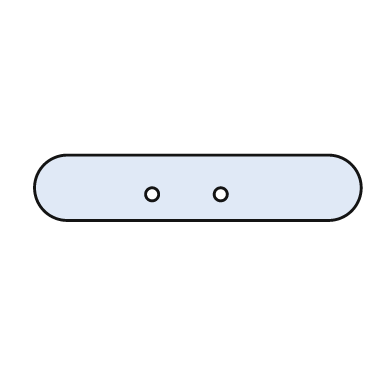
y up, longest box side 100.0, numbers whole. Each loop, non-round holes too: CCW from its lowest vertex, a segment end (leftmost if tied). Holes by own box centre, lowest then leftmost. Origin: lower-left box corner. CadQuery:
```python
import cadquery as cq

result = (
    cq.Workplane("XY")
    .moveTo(10.0, 0.0)
    .lineTo(90.0, 0.0)
    .threePointArc((100.0, 10.0), (90.0, 20.0))
    .lineTo(10.0, 20.0)
    .threePointArc((0.0, 10.0), (10.0, 0.0))
    .close()
    .moveTo(36.0, 8.0)
    .circle(2.0)
    .moveTo(57.0, 8.0)
    .circle(2.0)
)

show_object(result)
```